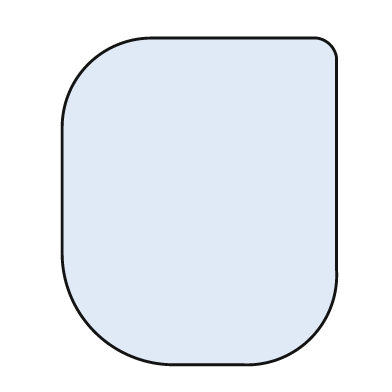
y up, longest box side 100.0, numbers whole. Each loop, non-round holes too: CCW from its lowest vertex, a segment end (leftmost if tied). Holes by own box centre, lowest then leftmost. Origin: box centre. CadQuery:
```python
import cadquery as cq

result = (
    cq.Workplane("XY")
    .moveTo(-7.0, -50.0)
    .lineTo(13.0, -50.0)
    .threePointArc((34.0, -42.0), (42.0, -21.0))
    .lineTo(42.0, 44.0)
    .threePointArc((40.0, 48.0), (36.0, 50.0))
    .lineTo(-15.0, 50.0)
    .threePointArc((-34.0, 42.0), (-42.0, 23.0))
    .lineTo(-42.0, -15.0)
    .threePointArc((-32.0, -40.0), (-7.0, -50.0))
    .close()
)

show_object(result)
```